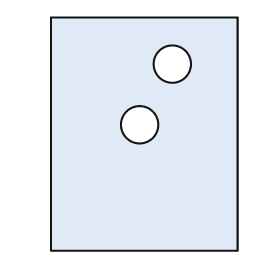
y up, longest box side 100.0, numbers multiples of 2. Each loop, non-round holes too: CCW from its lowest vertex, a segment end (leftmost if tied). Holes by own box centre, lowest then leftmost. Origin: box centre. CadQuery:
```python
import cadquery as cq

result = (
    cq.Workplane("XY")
    .moveTo(-40.0, -50.0)
    .lineTo(40.0, -50.0)
    .lineTo(40.0, 50.0)
    .lineTo(-40.0, 50.0)
    .close()
    .moveTo(-2.0, 4.0)
    .circle(8.0)
    .moveTo(12.0, 30.0)
    .circle(8.0)
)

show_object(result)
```